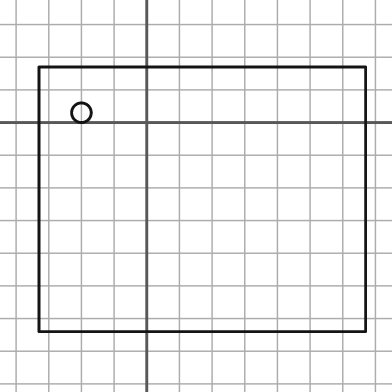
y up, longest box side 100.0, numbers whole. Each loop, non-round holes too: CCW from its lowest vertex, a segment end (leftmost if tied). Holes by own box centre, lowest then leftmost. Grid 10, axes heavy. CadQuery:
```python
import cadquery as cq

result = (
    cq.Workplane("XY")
    .moveTo(-33.0, -64.0)
    .lineTo(67.0, -64.0)
    .lineTo(67.0, 17.0)
    .lineTo(-33.0, 17.0)
    .close()
    .moveTo(-20.0, 3.0)
    .circle(3.0)
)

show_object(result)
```